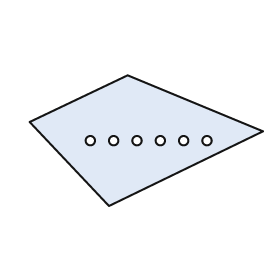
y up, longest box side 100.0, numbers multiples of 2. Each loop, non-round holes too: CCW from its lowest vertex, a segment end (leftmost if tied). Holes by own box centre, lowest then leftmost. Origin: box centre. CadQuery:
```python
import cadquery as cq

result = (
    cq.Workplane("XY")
    .moveTo(-16.0, -28.0)
    .lineTo(50.0, 4.0)
    .lineTo(-8.0, 28.0)
    .lineTo(-50.0, 8.0)
    .close()
    .moveTo(-24.0, 0.0)
    .circle(2.0)
    .moveTo(-14.0, 0.0)
    .circle(2.0)
    .moveTo(-4.0, 0.0)
    .circle(2.0)
    .moveTo(6.0, 0.0)
    .circle(2.0)
    .moveTo(16.0, 0.0)
    .circle(2.0)
    .moveTo(26.0, 0.0)
    .circle(2.0)
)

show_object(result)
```